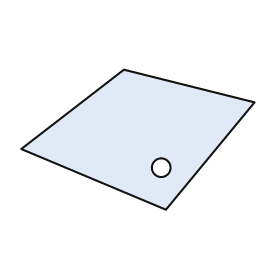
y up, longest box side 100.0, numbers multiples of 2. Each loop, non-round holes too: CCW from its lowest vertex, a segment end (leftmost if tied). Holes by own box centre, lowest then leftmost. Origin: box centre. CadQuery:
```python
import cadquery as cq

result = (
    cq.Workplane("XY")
    .moveTo(12.0, -30.0)
    .lineTo(50.0, 16.0)
    .lineTo(-6.0, 30.0)
    .lineTo(-50.0, -4.0)
    .close()
    .moveTo(10.0, -12.0)
    .circle(4.0)
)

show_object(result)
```